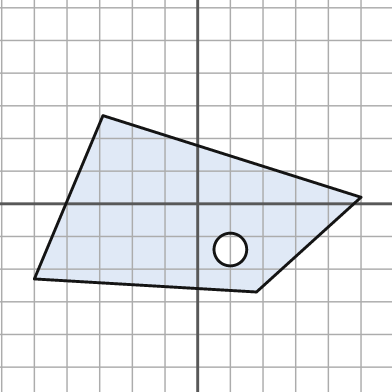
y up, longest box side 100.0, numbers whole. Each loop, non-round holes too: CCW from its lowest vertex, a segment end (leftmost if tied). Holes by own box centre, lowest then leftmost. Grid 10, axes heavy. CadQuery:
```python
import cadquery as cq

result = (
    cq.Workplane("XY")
    .moveTo(18.0, -27.0)
    .lineTo(50.0, 2.0)
    .lineTo(-29.0, 27.0)
    .lineTo(-50.0, -23.0)
    .close()
    .moveTo(10.0, -14.0)
    .circle(5.0)
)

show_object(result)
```